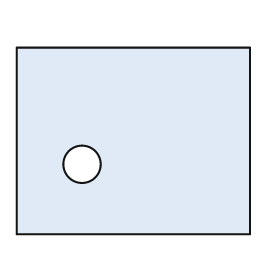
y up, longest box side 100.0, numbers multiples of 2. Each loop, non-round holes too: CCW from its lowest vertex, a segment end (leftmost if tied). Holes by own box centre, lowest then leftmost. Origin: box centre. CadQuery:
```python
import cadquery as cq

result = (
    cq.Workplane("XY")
    .moveTo(-50.0, -40.0)
    .lineTo(50.0, -40.0)
    .lineTo(50.0, 40.0)
    .lineTo(-50.0, 40.0)
    .close()
    .moveTo(-22.0, -10.0)
    .circle(8.0)
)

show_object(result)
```